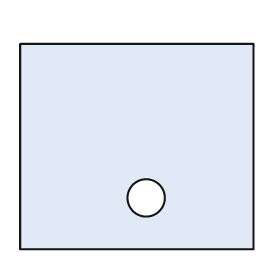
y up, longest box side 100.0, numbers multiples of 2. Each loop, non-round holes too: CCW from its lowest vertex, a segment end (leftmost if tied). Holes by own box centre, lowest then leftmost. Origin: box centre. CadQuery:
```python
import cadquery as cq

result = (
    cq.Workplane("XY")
    .moveTo(-50.0, -44.0)
    .lineTo(50.0, -44.0)
    .lineTo(50.0, 44.0)
    .lineTo(-50.0, 44.0)
    .close()
    .moveTo(4.0, -22.0)
    .circle(8.0)
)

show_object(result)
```